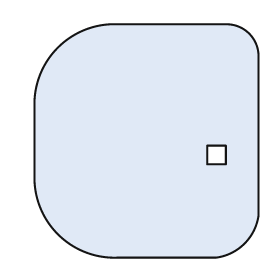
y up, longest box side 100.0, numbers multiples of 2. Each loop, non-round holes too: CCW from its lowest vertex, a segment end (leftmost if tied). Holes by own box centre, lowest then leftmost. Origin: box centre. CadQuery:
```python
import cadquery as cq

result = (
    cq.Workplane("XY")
    .moveTo(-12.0, -50.0)
    .lineTo(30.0, -50.0)
    .threePointArc((42.0, -44.0), (48.0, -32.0))
    .lineTo(48.0, 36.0)
    .threePointArc((44.0, 46.0), (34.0, 50.0))
    .lineTo(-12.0, 50.0)
    .threePointArc((-38.0, 40.0), (-48.0, 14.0))
    .lineTo(-48.0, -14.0)
    .threePointArc((-38.0, -40.0), (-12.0, -50.0))
    .close()
    .moveTo(26.0, -10.0)
    .lineTo(34.0, -10.0)
    .lineTo(34.0, -2.0)
    .lineTo(26.0, -2.0)
    .close()
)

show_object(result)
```